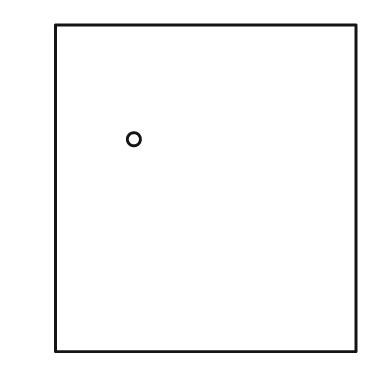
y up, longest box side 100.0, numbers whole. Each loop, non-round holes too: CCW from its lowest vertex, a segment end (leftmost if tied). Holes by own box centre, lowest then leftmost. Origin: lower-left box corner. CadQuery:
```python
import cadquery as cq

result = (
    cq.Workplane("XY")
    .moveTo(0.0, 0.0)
    .lineTo(92.0, 0.0)
    .lineTo(92.0, 100.0)
    .lineTo(0.0, 100.0)
    .close()
    .moveTo(24.0, 65.0)
    .circle(2.0)
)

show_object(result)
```